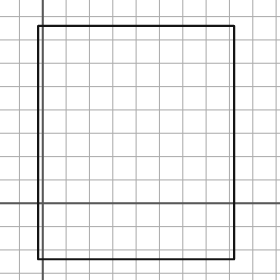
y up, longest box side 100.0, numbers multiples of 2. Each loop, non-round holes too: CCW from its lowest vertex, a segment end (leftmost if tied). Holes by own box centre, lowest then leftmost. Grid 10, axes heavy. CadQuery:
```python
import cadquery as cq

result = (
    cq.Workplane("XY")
    .moveTo(-2.0, -24.0)
    .lineTo(82.0, -24.0)
    .lineTo(82.0, 76.0)
    .lineTo(-2.0, 76.0)
    .close()
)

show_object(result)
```